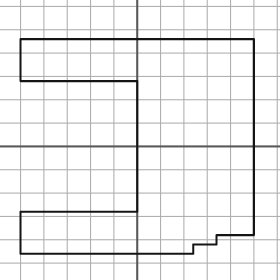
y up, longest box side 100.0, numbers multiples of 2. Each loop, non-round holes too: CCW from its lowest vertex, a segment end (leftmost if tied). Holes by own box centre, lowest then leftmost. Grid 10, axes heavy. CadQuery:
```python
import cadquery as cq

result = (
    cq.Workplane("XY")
    .moveTo(-50.0, -46.0)
    .lineTo(24.0, -46.0)
    .lineTo(24.0, -42.0)
    .lineTo(34.0, -42.0)
    .lineTo(34.0, -38.0)
    .lineTo(50.0, -38.0)
    .lineTo(50.0, 46.0)
    .lineTo(-50.0, 46.0)
    .lineTo(-50.0, 28.0)
    .lineTo(0.0, 28.0)
    .lineTo(0.0, -28.0)
    .lineTo(-50.0, -28.0)
    .close()
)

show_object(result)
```